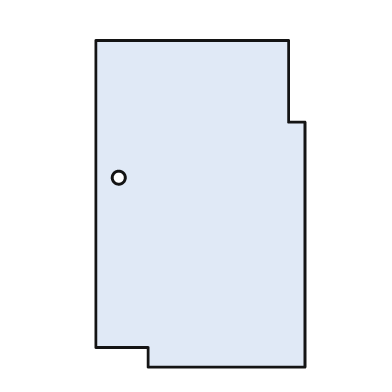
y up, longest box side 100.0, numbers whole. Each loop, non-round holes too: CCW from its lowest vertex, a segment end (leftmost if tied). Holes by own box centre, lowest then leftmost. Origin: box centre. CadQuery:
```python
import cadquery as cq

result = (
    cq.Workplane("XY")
    .moveTo(-16.0, -50.0)
    .lineTo(32.0, -50.0)
    .lineTo(32.0, 25.0)
    .lineTo(27.0, 25.0)
    .lineTo(27.0, 50.0)
    .lineTo(-32.0, 50.0)
    .lineTo(-32.0, -44.0)
    .lineTo(-16.0, -44.0)
    .close()
    .moveTo(-25.0, 8.0)
    .circle(2.0)
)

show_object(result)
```